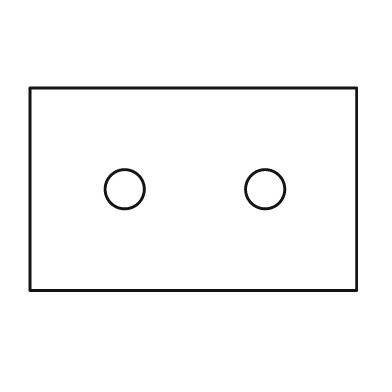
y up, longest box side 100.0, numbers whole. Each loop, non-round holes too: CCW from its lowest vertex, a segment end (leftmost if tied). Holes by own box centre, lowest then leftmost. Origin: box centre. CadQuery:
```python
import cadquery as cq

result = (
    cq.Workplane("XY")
    .moveTo(-50.0, -31.0)
    .lineTo(50.0, -31.0)
    .lineTo(50.0, 31.0)
    .lineTo(-50.0, 31.0)
    .close()
    .moveTo(-21.0, 0.0)
    .circle(6.0)
    .moveTo(22.0, 0.0)
    .circle(6.0)
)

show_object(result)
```